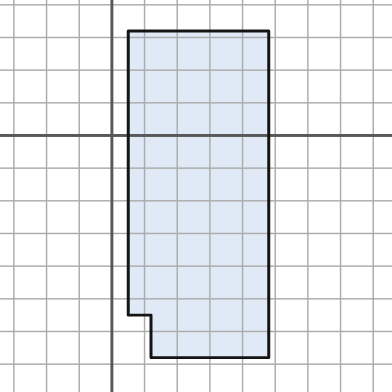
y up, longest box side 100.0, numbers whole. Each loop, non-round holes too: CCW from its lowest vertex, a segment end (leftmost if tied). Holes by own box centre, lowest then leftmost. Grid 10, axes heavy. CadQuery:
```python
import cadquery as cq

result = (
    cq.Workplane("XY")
    .moveTo(12.0, -68.0)
    .lineTo(48.0, -68.0)
    .lineTo(48.0, 32.0)
    .lineTo(5.0, 32.0)
    .lineTo(5.0, -55.0)
    .lineTo(12.0, -55.0)
    .close()
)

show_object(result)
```